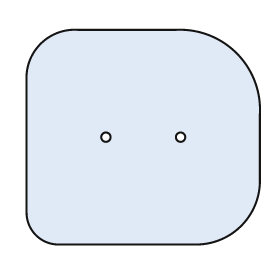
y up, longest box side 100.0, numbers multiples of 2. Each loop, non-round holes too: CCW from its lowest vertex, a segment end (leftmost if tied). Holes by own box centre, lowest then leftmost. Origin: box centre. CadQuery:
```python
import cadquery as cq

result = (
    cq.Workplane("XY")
    .moveTo(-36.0, -46.0)
    .lineTo(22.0, -46.0)
    .threePointArc((42.0, -38.0), (50.0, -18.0))
    .lineTo(50.0, 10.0)
    .threePointArc((40.0, 36.0), (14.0, 46.0))
    .lineTo(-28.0, 46.0)
    .threePointArc((-44.0, 40.0), (-50.0, 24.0))
    .lineTo(-50.0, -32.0)
    .threePointArc((-46.0, -42.0), (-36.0, -46.0))
    .close()
    .moveTo(-16.0, 0.0)
    .circle(2.0)
    .moveTo(16.0, 0.0)
    .circle(2.0)
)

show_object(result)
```